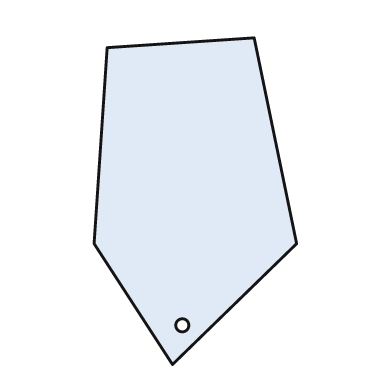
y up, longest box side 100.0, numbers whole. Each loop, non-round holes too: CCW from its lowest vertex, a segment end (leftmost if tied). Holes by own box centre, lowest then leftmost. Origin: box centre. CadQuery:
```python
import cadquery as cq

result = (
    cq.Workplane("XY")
    .moveTo(-7.0, -50.0)
    .lineTo(31.0, -13.0)
    .lineTo(18.0, 50.0)
    .lineTo(-27.0, 47.0)
    .lineTo(-31.0, -13.0)
    .close()
    .moveTo(-4.0, -38.0)
    .circle(2.0)
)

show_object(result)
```